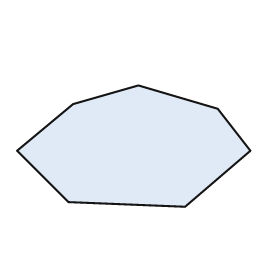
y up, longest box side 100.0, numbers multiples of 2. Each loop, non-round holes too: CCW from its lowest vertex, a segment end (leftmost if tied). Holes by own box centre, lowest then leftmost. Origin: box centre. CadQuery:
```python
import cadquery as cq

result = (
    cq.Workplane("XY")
    .moveTo(22.0, -26.0)
    .lineTo(50.0, -2.0)
    .lineTo(36.0, 16.0)
    .lineTo(2.0, 26.0)
    .lineTo(-26.0, 18.0)
    .lineTo(-50.0, -2.0)
    .lineTo(-28.0, -24.0)
    .close()
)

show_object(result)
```